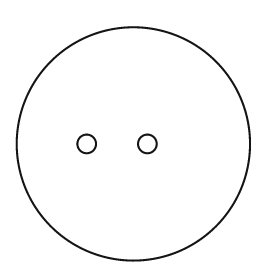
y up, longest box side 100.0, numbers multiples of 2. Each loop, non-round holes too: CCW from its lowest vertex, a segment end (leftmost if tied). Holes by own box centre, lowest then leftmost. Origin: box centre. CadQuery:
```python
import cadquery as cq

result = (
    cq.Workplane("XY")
    .moveTo(0.0, 0.0)
    .circle(50.0)
    .moveTo(-20.0, 0.0)
    .circle(4.0)
    .moveTo(6.0, 0.0)
    .circle(4.0)
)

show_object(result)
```